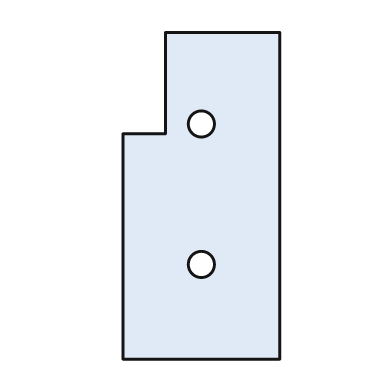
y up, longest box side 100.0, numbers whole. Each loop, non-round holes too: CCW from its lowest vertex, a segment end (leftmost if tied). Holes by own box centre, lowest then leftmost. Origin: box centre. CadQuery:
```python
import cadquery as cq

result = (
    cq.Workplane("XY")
    .moveTo(-24.0, -50.0)
    .lineTo(24.0, -50.0)
    .lineTo(24.0, 50.0)
    .lineTo(-11.0, 50.0)
    .lineTo(-11.0, 19.0)
    .lineTo(-24.0, 19.0)
    .close()
    .moveTo(0.0, -21.0)
    .circle(4.0)
    .moveTo(0.0, 22.0)
    .circle(4.0)
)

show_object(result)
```